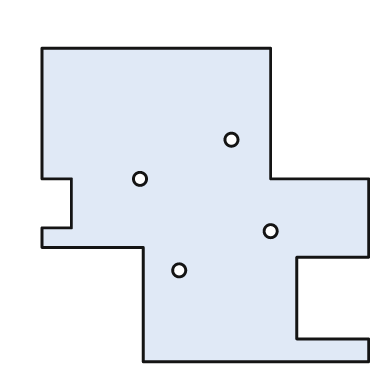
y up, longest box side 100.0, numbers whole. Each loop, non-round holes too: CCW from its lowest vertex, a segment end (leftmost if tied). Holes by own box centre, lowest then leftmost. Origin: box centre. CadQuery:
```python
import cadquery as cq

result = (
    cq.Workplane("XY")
    .moveTo(-19.0, -48.0)
    .lineTo(50.0, -48.0)
    .lineTo(50.0, -41.0)
    .lineTo(28.0, -41.0)
    .lineTo(28.0, -16.0)
    .lineTo(50.0, -16.0)
    .lineTo(50.0, 8.0)
    .lineTo(20.0, 8.0)
    .lineTo(20.0, 48.0)
    .lineTo(-50.0, 48.0)
    .lineTo(-50.0, 8.0)
    .lineTo(-41.0, 8.0)
    .lineTo(-41.0, -7.0)
    .lineTo(-50.0, -7.0)
    .lineTo(-50.0, -13.0)
    .lineTo(-19.0, -13.0)
    .close()
    .moveTo(-8.0, -20.0)
    .circle(2.0)
    .moveTo(20.0, -8.0)
    .circle(2.0)
    .moveTo(-20.0, 8.0)
    .circle(2.0)
    .moveTo(8.0, 20.0)
    .circle(2.0)
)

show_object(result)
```